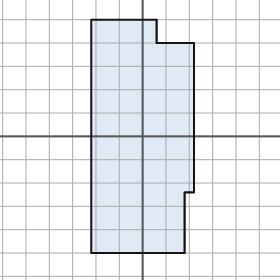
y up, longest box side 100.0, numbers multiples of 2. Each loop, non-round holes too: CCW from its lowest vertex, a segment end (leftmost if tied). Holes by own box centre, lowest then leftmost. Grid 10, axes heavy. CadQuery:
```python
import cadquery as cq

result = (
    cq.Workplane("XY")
    .moveTo(-22.0, -50.0)
    .lineTo(18.0, -50.0)
    .lineTo(18.0, -24.0)
    .lineTo(22.0, -24.0)
    .lineTo(22.0, 40.0)
    .lineTo(6.0, 40.0)
    .lineTo(6.0, 50.0)
    .lineTo(-22.0, 50.0)
    .close()
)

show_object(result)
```